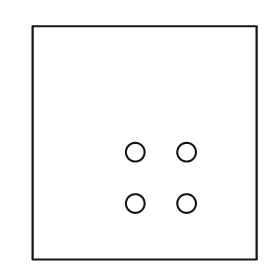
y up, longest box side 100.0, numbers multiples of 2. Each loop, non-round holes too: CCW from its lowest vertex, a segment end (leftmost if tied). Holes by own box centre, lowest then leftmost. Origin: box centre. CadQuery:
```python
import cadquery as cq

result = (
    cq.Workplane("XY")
    .moveTo(-48.0, -50.0)
    .lineTo(48.0, -50.0)
    .lineTo(48.0, 50.0)
    .lineTo(-48.0, 50.0)
    .close()
    .moveTo(-4.0, -26.0)
    .circle(4.0)
    .moveTo(18.0, -26.0)
    .circle(4.0)
    .moveTo(-4.0, -4.0)
    .circle(4.0)
    .moveTo(18.0, -4.0)
    .circle(4.0)
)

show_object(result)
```